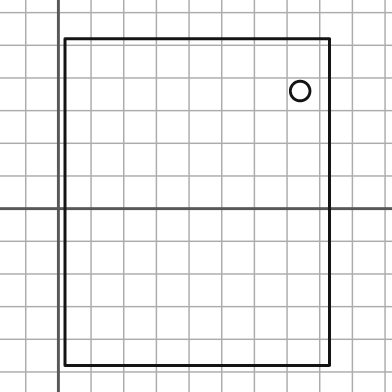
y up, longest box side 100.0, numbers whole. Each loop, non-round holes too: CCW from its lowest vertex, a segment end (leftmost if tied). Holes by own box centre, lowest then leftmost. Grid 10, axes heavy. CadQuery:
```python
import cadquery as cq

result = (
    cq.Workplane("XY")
    .moveTo(2.0, -48.0)
    .lineTo(83.0, -48.0)
    .lineTo(83.0, 52.0)
    .lineTo(2.0, 52.0)
    .close()
    .moveTo(74.0, 36.0)
    .circle(3.0)
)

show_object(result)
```